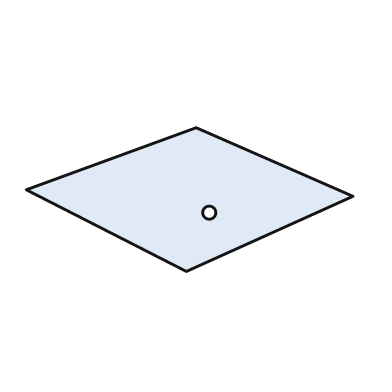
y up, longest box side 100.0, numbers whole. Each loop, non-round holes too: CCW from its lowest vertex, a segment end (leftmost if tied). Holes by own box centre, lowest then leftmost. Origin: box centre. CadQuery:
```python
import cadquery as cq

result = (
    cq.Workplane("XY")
    .moveTo(-1.0, -22.0)
    .lineTo(50.0, 1.0)
    .lineTo(2.0, 22.0)
    .lineTo(-50.0, 3.0)
    .close()
    .moveTo(6.0, -4.0)
    .circle(2.0)
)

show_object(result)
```